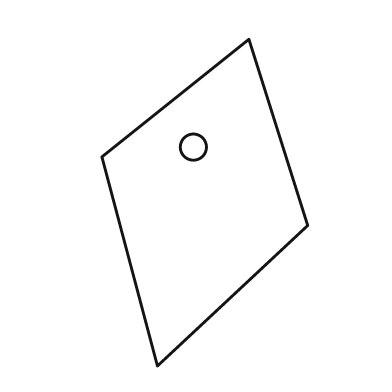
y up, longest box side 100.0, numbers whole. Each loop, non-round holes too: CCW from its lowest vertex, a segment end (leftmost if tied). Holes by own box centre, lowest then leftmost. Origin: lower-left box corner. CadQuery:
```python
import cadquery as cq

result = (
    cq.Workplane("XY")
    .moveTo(17.0, 0.0)
    .lineTo(63.0, 43.0)
    .lineTo(45.0, 100.0)
    .lineTo(0.0, 64.0)
    .close()
    .moveTo(28.0, 67.0)
    .circle(4.0)
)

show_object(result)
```